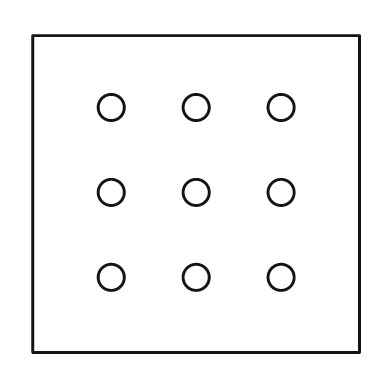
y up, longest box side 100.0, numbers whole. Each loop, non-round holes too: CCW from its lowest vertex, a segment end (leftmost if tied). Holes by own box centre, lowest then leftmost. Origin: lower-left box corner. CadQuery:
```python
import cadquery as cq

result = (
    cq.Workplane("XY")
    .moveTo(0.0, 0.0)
    .lineTo(100.0, 0.0)
    .lineTo(100.0, 97.0)
    .lineTo(0.0, 97.0)
    .close()
    .moveTo(24.0, 23.0)
    .circle(4.0)
    .moveTo(50.0, 23.0)
    .circle(4.0)
    .moveTo(76.0, 23.0)
    .circle(4.0)
    .moveTo(24.0, 49.0)
    .circle(4.0)
    .moveTo(50.0, 49.0)
    .circle(4.0)
    .moveTo(76.0, 49.0)
    .circle(4.0)
    .moveTo(24.0, 75.0)
    .circle(4.0)
    .moveTo(50.0, 75.0)
    .circle(4.0)
    .moveTo(76.0, 75.0)
    .circle(4.0)
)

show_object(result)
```